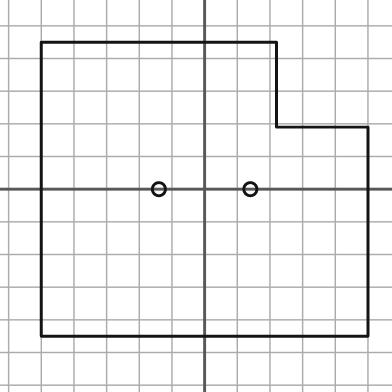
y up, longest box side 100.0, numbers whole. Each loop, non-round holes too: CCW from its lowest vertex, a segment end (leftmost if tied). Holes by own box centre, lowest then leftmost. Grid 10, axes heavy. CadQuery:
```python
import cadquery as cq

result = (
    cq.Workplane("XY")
    .moveTo(-50.0, -45.0)
    .lineTo(50.0, -45.0)
    .lineTo(50.0, 19.0)
    .lineTo(22.0, 19.0)
    .lineTo(22.0, 45.0)
    .lineTo(-50.0, 45.0)
    .close()
    .moveTo(-14.0, 0.0)
    .circle(2.0)
    .moveTo(14.0, 0.0)
    .circle(2.0)
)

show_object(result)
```